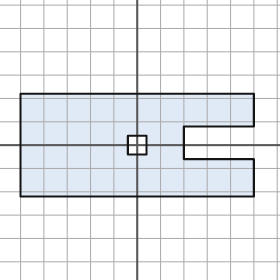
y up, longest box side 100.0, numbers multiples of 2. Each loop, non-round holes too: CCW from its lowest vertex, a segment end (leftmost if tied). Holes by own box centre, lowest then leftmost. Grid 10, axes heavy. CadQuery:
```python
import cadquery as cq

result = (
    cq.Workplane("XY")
    .moveTo(-50.0, -22.0)
    .lineTo(50.0, -22.0)
    .lineTo(50.0, -6.0)
    .lineTo(20.0, -6.0)
    .lineTo(20.0, 8.0)
    .lineTo(50.0, 8.0)
    .lineTo(50.0, 22.0)
    .lineTo(-50.0, 22.0)
    .close()
    .moveTo(-4.0, -4.0)
    .lineTo(4.0, -4.0)
    .lineTo(4.0, 4.0)
    .lineTo(-4.0, 4.0)
    .close()
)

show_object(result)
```